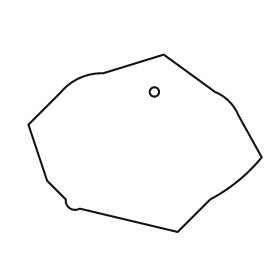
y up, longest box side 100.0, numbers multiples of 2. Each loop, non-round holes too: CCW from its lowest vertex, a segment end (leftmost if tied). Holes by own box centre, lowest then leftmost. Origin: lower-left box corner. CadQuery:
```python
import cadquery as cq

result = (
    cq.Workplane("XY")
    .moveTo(64.0, 0.0)
    .lineTo(78.0, 14.0)
    .threePointArc((90.0, 22.0), (100.0, 32.0))
    .lineTo(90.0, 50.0)
    .threePointArc((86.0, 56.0), (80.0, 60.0))
    .lineTo(58.0, 76.0)
    .lineTo(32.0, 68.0)
    .threePointArc((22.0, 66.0), (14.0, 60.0))
    .lineTo(0.0, 46.0)
    .lineTo(8.0, 22.0)
    .lineTo(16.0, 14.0)
    .threePointArc((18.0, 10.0), (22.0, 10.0))
    .close()
    .moveTo(54.0, 60.0)
    .circle(2.0)
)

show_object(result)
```